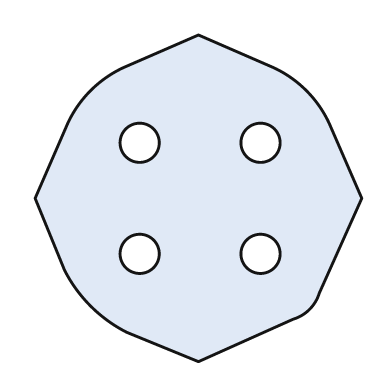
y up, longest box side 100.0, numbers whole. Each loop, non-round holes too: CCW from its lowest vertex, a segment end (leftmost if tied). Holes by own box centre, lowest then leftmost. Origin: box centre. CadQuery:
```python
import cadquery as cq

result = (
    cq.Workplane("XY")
    .moveTo(0.0, -50.0)
    .lineTo(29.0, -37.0)
    .threePointArc((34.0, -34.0), (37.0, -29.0))
    .lineTo(50.0, 0.0)
    .lineTo(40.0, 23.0)
    .threePointArc((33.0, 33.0), (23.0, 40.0))
    .lineTo(0.0, 50.0)
    .lineTo(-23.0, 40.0)
    .threePointArc((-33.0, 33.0), (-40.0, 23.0))
    .lineTo(-50.0, 0.0)
    .lineTo(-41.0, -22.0)
    .threePointArc((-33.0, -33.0), (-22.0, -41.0))
    .close()
    .moveTo(-18.0, -17.0)
    .circle(6.0)
    .moveTo(19.0, -17.0)
    .circle(6.0)
    .moveTo(-18.0, 17.0)
    .circle(6.0)
    .moveTo(19.0, 17.0)
    .circle(6.0)
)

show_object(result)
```